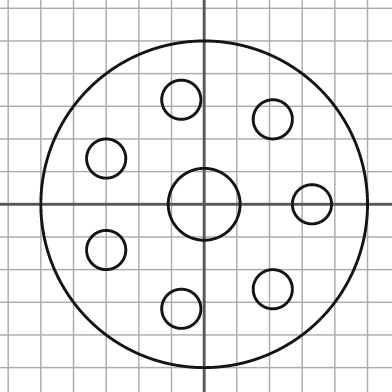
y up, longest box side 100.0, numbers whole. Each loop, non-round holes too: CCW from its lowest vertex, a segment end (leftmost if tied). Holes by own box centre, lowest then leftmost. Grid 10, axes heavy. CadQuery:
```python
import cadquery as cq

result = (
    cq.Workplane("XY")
    .moveTo(0.0, 0.0)
    .circle(50.0)
    .moveTo(-7.0, -32.0)
    .circle(6.0)
    .moveTo(21.0, -26.0)
    .circle(6.0)
    .moveTo(-30.0, -14.0)
    .circle(6.0)
    .moveTo(0.0, 0.0)
    .circle(11.0)
    .moveTo(33.0, 0.0)
    .circle(6.0)
    .moveTo(-30.0, 14.0)
    .circle(6.0)
    .moveTo(21.0, 26.0)
    .circle(6.0)
    .moveTo(-7.0, 32.0)
    .circle(6.0)
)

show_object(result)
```